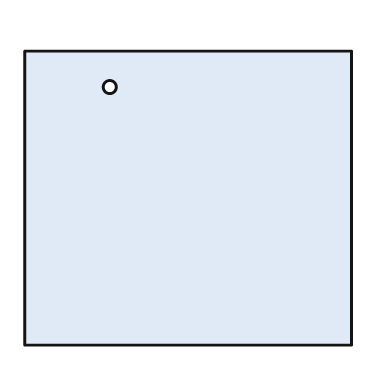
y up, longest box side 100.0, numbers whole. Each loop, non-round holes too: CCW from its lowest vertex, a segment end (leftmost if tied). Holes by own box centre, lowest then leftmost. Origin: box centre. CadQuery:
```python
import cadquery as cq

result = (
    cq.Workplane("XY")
    .moveTo(-50.0, -45.0)
    .lineTo(50.0, -45.0)
    .lineTo(50.0, 45.0)
    .lineTo(-50.0, 45.0)
    .close()
    .moveTo(-24.0, 34.0)
    .circle(2.0)
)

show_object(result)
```